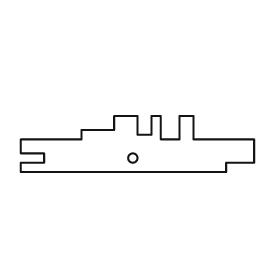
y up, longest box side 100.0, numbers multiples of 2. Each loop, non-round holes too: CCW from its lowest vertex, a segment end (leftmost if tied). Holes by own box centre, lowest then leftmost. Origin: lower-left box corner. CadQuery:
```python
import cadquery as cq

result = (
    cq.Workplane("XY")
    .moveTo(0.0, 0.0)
    .lineTo(88.0, 0.0)
    .lineTo(88.0, 4.0)
    .lineTo(100.0, 4.0)
    .lineTo(100.0, 14.0)
    .lineTo(74.0, 14.0)
    .lineTo(74.0, 24.0)
    .lineTo(68.0, 24.0)
    .lineTo(68.0, 14.0)
    .lineTo(60.0, 14.0)
    .lineTo(60.0, 24.0)
    .lineTo(56.0, 24.0)
    .lineTo(56.0, 16.0)
    .lineTo(50.0, 16.0)
    .lineTo(50.0, 24.0)
    .lineTo(40.0, 24.0)
    .lineTo(40.0, 18.0)
    .lineTo(26.0, 18.0)
    .lineTo(26.0, 14.0)
    .lineTo(0.0, 14.0)
    .lineTo(0.0, 8.0)
    .lineTo(10.0, 8.0)
    .lineTo(10.0, 4.0)
    .lineTo(0.0, 4.0)
    .close()
    .moveTo(48.0, 6.0)
    .circle(2.0)
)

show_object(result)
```